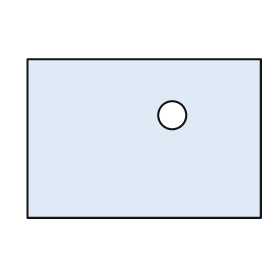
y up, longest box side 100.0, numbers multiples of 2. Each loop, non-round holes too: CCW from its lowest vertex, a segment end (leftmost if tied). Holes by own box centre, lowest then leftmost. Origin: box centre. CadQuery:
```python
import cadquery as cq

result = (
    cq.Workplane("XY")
    .moveTo(-50.0, -34.0)
    .lineTo(50.0, -34.0)
    .lineTo(50.0, 34.0)
    .lineTo(-50.0, 34.0)
    .close()
    .moveTo(12.0, 10.0)
    .circle(6.0)
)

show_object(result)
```